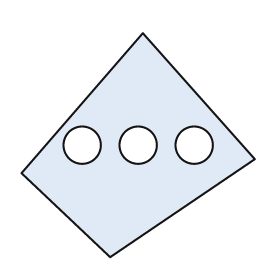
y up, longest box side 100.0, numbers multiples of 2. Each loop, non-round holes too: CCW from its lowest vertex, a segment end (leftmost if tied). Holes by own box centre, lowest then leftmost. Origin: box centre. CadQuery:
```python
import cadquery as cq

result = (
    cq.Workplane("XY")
    .moveTo(-12.0, -48.0)
    .lineTo(50.0, -6.0)
    .lineTo(2.0, 48.0)
    .lineTo(-50.0, -12.0)
    .close()
    .moveTo(-24.0, 0.0)
    .circle(8.0)
    .moveTo(0.0, 0.0)
    .circle(8.0)
    .moveTo(24.0, 0.0)
    .circle(8.0)
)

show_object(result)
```